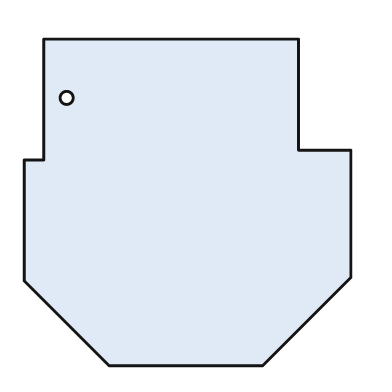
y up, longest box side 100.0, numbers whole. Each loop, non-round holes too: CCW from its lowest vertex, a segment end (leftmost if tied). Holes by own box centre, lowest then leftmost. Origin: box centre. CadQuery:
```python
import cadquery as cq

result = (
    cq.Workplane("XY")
    .moveTo(-24.0, -50.0)
    .lineTo(23.0, -50.0)
    .lineTo(50.0, -23.0)
    .lineTo(50.0, 16.0)
    .lineTo(34.0, 16.0)
    .lineTo(34.0, 50.0)
    .lineTo(-44.0, 50.0)
    .lineTo(-44.0, 13.0)
    .lineTo(-50.0, 13.0)
    .lineTo(-50.0, -24.0)
    .close()
    .moveTo(-37.0, 32.0)
    .circle(2.0)
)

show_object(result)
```